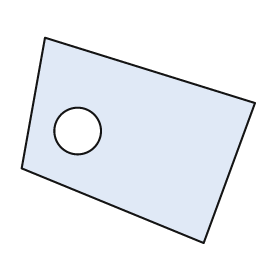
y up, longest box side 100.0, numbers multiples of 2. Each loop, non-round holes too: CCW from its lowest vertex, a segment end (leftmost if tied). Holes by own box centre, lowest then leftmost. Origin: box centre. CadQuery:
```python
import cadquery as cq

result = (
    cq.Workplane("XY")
    .moveTo(28.0, -44.0)
    .lineTo(50.0, 16.0)
    .lineTo(-40.0, 44.0)
    .lineTo(-50.0, -12.0)
    .close()
    .moveTo(-26.0, 4.0)
    .circle(10.0)
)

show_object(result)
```